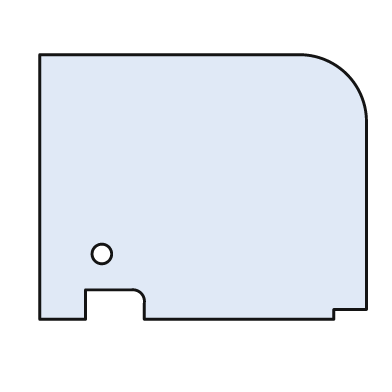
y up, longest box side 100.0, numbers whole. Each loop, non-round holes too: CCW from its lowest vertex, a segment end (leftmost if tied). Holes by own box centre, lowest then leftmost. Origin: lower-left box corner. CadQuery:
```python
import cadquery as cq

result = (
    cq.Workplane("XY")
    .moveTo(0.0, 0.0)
    .lineTo(14.0, 0.0)
    .lineTo(14.0, 9.0)
    .lineTo(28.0, 9.0)
    .threePointArc((31.0, 8.0), (32.0, 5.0))
    .lineTo(32.0, 0.0)
    .lineTo(90.0, 0.0)
    .lineTo(90.0, 3.0)
    .lineTo(100.0, 3.0)
    .lineTo(100.0, 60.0)
    .threePointArc((94.0, 75.0), (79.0, 81.0))
    .lineTo(0.0, 81.0)
    .close()
    .moveTo(19.0, 20.0)
    .circle(3.0)
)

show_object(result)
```